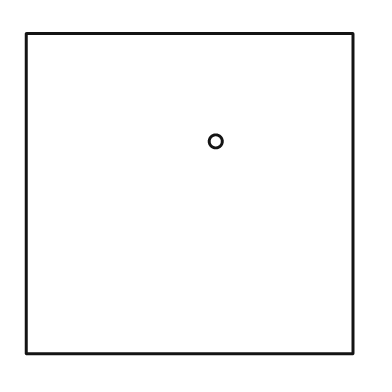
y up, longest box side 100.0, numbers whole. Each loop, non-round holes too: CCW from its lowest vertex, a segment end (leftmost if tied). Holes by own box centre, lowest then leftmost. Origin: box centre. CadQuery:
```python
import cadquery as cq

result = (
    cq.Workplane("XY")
    .moveTo(-50.0, -49.0)
    .lineTo(50.0, -49.0)
    .lineTo(50.0, 49.0)
    .lineTo(-50.0, 49.0)
    .close()
    .moveTo(8.0, 16.0)
    .circle(2.0)
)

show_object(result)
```